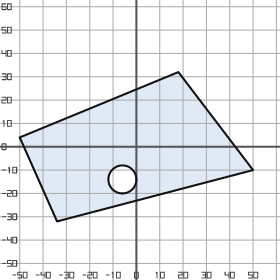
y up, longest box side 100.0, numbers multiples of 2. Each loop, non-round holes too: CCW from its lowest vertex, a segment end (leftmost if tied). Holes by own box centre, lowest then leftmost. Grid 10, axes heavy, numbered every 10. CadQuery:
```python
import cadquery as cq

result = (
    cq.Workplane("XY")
    .moveTo(-34.0, -32.0)
    .lineTo(50.0, -10.0)
    .lineTo(18.0, 32.0)
    .lineTo(-50.0, 4.0)
    .close()
    .moveTo(-6.0, -14.0)
    .circle(6.0)
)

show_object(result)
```